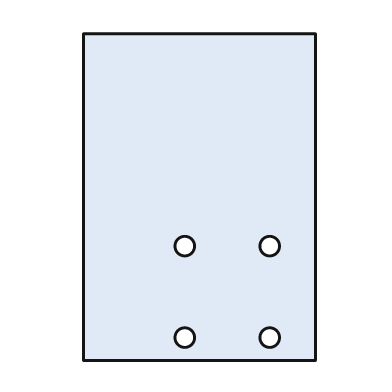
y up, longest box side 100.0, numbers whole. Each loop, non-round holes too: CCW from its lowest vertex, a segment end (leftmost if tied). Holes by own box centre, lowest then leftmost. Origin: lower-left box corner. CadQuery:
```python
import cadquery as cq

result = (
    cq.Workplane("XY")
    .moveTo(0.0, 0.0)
    .lineTo(71.0, 0.0)
    .lineTo(71.0, 100.0)
    .lineTo(0.0, 100.0)
    .close()
    .moveTo(31.0, 7.0)
    .circle(3.0)
    .moveTo(57.0, 7.0)
    .circle(3.0)
    .moveTo(31.0, 35.0)
    .circle(3.0)
    .moveTo(57.0, 35.0)
    .circle(3.0)
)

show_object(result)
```